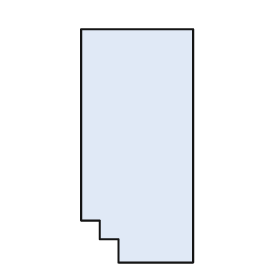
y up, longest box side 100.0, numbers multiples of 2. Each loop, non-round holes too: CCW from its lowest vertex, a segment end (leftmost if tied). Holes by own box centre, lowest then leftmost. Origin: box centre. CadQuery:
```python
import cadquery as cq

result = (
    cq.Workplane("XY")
    .moveTo(-8.0, -50.0)
    .lineTo(24.0, -50.0)
    .lineTo(24.0, 50.0)
    .lineTo(-24.0, 50.0)
    .lineTo(-24.0, -32.0)
    .lineTo(-16.0, -32.0)
    .lineTo(-16.0, -40.0)
    .lineTo(-8.0, -40.0)
    .close()
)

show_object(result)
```